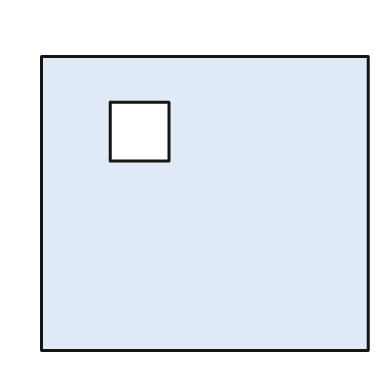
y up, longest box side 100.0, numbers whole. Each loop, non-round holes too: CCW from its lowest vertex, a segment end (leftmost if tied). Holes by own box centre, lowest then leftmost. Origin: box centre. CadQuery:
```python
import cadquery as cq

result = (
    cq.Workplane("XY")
    .moveTo(-50.0, -45.0)
    .lineTo(50.0, -45.0)
    .lineTo(50.0, 45.0)
    .lineTo(-50.0, 45.0)
    .close()
    .moveTo(-29.0, 13.0)
    .lineTo(-11.0, 13.0)
    .lineTo(-11.0, 31.0)
    .lineTo(-29.0, 31.0)
    .close()
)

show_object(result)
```